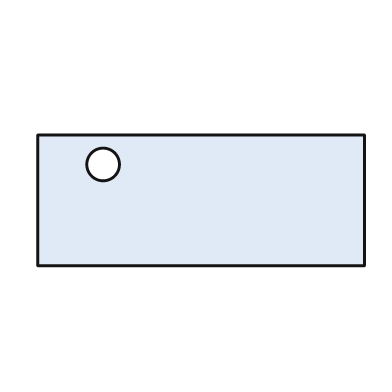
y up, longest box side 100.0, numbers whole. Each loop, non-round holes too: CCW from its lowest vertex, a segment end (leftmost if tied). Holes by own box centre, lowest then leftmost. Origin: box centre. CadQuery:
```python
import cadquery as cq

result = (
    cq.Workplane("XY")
    .moveTo(-50.0, -20.0)
    .lineTo(50.0, -20.0)
    .lineTo(50.0, 20.0)
    .lineTo(-50.0, 20.0)
    .close()
    .moveTo(-30.0, 11.0)
    .circle(5.0)
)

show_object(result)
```